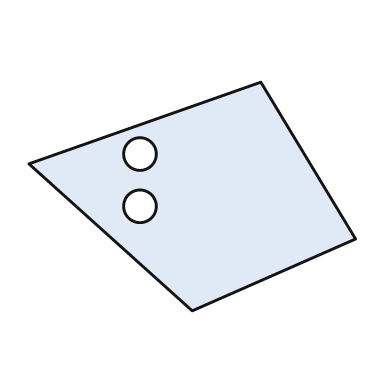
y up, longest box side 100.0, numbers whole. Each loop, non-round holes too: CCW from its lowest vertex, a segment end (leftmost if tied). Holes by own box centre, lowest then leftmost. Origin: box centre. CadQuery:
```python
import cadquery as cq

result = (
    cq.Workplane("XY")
    .moveTo(0.0, -35.0)
    .lineTo(50.0, -13.0)
    .lineTo(21.0, 35.0)
    .lineTo(-50.0, 10.0)
    .close()
    .moveTo(-16.0, -3.0)
    .circle(5.0)
    .moveTo(-16.0, 13.0)
    .circle(5.0)
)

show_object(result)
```